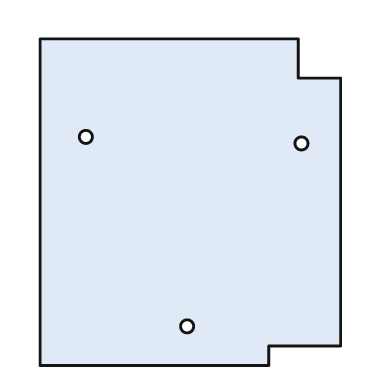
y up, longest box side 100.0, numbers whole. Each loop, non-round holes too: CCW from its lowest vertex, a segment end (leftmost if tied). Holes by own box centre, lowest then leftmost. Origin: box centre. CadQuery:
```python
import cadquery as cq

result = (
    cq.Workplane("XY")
    .moveTo(-46.0, -50.0)
    .lineTo(24.0, -50.0)
    .lineTo(24.0, -44.0)
    .lineTo(46.0, -44.0)
    .lineTo(46.0, 38.0)
    .lineTo(33.0, 38.0)
    .lineTo(33.0, 50.0)
    .lineTo(-46.0, 50.0)
    .close()
    .moveTo(-1.0, -38.0)
    .circle(2.0)
    .moveTo(34.0, 18.0)
    .circle(2.0)
    .moveTo(-32.0, 20.0)
    .circle(2.0)
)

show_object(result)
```